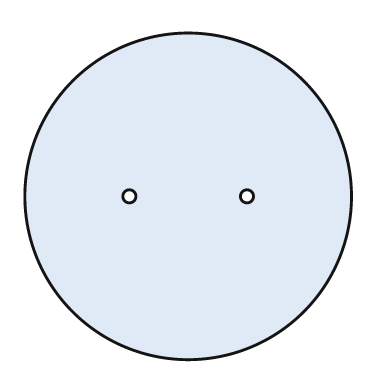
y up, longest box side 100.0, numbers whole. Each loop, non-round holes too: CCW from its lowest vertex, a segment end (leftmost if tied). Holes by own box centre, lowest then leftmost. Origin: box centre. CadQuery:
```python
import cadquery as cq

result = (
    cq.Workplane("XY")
    .moveTo(0.0, 0.0)
    .circle(50.0)
    .moveTo(-18.0, 0.0)
    .circle(2.0)
    .moveTo(18.0, 0.0)
    .circle(2.0)
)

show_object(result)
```